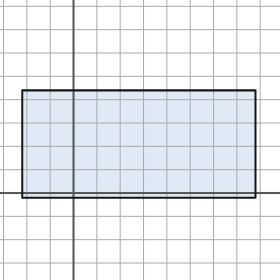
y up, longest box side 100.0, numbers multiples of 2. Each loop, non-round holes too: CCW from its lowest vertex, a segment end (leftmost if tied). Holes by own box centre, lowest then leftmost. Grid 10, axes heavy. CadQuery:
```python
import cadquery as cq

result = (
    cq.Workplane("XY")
    .moveTo(-22.0, -2.0)
    .lineTo(78.0, -2.0)
    .lineTo(78.0, 44.0)
    .lineTo(-22.0, 44.0)
    .close()
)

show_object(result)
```